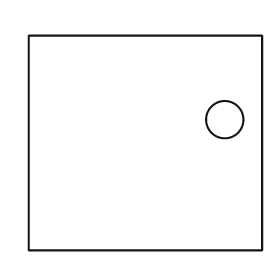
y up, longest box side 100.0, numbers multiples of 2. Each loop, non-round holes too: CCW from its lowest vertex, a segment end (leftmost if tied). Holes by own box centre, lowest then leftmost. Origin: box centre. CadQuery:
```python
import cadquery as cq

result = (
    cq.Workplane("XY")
    .moveTo(-50.0, -46.0)
    .lineTo(50.0, -46.0)
    .lineTo(50.0, 46.0)
    .lineTo(-50.0, 46.0)
    .close()
    .moveTo(34.0, 10.0)
    .circle(8.0)
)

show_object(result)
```